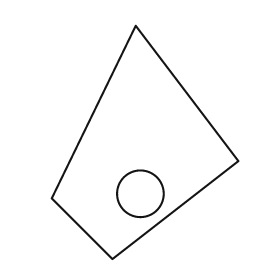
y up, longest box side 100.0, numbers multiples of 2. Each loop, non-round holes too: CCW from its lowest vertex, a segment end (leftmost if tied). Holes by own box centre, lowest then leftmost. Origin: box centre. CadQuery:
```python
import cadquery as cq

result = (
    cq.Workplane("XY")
    .moveTo(-14.0, -50.0)
    .lineTo(40.0, -8.0)
    .lineTo(-4.0, 50.0)
    .lineTo(-40.0, -24.0)
    .close()
    .moveTo(-2.0, -22.0)
    .circle(10.0)
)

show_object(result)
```